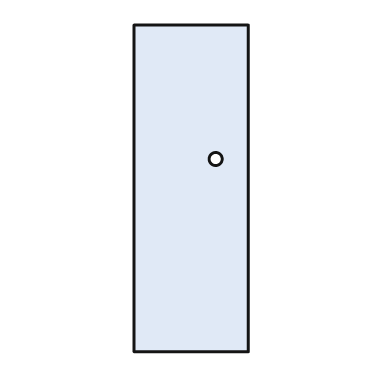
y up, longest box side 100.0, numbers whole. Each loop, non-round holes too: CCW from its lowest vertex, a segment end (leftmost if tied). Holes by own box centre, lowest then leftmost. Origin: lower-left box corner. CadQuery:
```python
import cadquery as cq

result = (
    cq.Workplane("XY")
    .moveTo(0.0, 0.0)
    .lineTo(35.0, 0.0)
    .lineTo(35.0, 100.0)
    .lineTo(0.0, 100.0)
    .close()
    .moveTo(25.0, 59.0)
    .circle(2.0)
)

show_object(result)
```